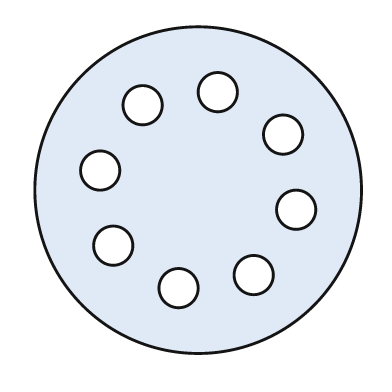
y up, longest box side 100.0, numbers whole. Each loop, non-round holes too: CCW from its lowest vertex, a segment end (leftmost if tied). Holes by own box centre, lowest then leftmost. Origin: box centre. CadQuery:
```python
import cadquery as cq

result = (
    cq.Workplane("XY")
    .moveTo(0.0, 0.0)
    .circle(50.0)
    .moveTo(-6.0, -30.0)
    .circle(6.0)
    .moveTo(17.0, -26.0)
    .circle(6.0)
    .moveTo(-26.0, -17.0)
    .circle(6.0)
    .moveTo(30.0, -6.0)
    .circle(6.0)
    .moveTo(-30.0, 6.0)
    .circle(6.0)
    .moveTo(26.0, 17.0)
    .circle(6.0)
    .moveTo(-17.0, 26.0)
    .circle(6.0)
    .moveTo(6.0, 30.0)
    .circle(6.0)
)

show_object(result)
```